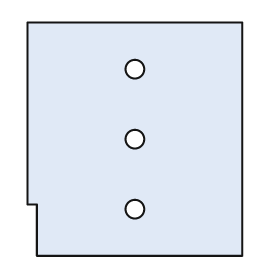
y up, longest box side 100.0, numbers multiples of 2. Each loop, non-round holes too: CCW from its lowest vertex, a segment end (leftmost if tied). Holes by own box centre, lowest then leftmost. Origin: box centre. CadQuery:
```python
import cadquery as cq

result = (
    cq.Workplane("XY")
    .moveTo(-42.0, -50.0)
    .lineTo(46.0, -50.0)
    .lineTo(46.0, 50.0)
    .lineTo(-46.0, 50.0)
    .lineTo(-46.0, -28.0)
    .lineTo(-42.0, -28.0)
    .close()
    .moveTo(0.0, -30.0)
    .circle(4.0)
    .moveTo(0.0, 0.0)
    .circle(4.0)
    .moveTo(0.0, 30.0)
    .circle(4.0)
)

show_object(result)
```